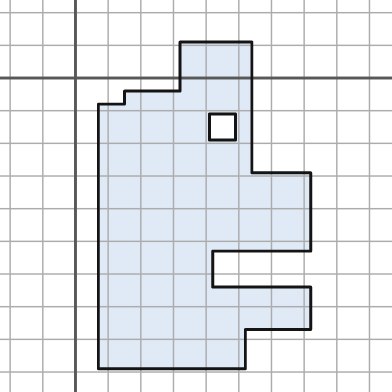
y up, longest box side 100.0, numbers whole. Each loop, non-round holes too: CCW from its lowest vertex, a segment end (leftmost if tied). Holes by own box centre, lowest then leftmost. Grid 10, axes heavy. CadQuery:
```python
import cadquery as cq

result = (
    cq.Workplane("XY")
    .moveTo(7.0, -89.0)
    .lineTo(52.0, -89.0)
    .lineTo(52.0, -77.0)
    .lineTo(72.0, -77.0)
    .lineTo(72.0, -64.0)
    .lineTo(42.0, -64.0)
    .lineTo(42.0, -53.0)
    .lineTo(72.0, -53.0)
    .lineTo(72.0, -29.0)
    .lineTo(54.0, -29.0)
    .lineTo(54.0, 11.0)
    .lineTo(32.0, 11.0)
    .lineTo(32.0, -4.0)
    .lineTo(15.0, -4.0)
    .lineTo(15.0, -8.0)
    .lineTo(7.0, -8.0)
    .close()
    .moveTo(41.0, -19.0)
    .lineTo(49.0, -19.0)
    .lineTo(49.0, -11.0)
    .lineTo(41.0, -11.0)
    .close()
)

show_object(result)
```